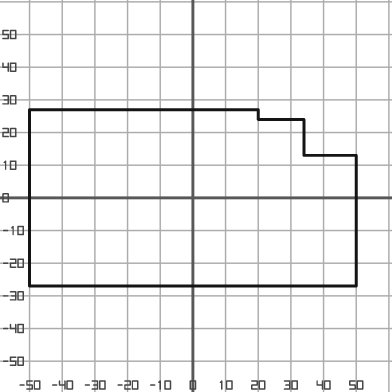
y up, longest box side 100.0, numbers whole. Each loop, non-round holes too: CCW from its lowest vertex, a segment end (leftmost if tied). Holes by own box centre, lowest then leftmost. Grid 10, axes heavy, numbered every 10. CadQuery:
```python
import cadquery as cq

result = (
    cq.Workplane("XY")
    .moveTo(-50.0, -27.0)
    .lineTo(50.0, -27.0)
    .lineTo(50.0, 13.0)
    .lineTo(34.0, 13.0)
    .lineTo(34.0, 24.0)
    .lineTo(20.0, 24.0)
    .lineTo(20.0, 27.0)
    .lineTo(-50.0, 27.0)
    .close()
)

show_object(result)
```